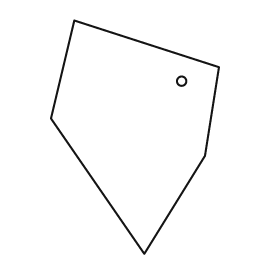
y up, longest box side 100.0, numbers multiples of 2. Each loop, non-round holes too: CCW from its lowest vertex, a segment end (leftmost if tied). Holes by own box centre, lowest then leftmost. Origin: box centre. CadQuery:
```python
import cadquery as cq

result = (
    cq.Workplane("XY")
    .moveTo(4.0, -50.0)
    .lineTo(30.0, -8.0)
    .lineTo(36.0, 30.0)
    .lineTo(-26.0, 50.0)
    .lineTo(-36.0, 8.0)
    .close()
    .moveTo(20.0, 24.0)
    .circle(2.0)
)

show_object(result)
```